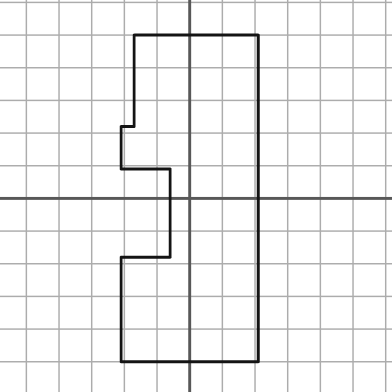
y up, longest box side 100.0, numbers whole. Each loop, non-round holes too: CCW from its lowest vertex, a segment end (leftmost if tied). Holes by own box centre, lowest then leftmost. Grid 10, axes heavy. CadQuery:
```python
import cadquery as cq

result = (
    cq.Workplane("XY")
    .moveTo(-21.0, -50.0)
    .lineTo(21.0, -50.0)
    .lineTo(21.0, 50.0)
    .lineTo(-17.0, 50.0)
    .lineTo(-17.0, 22.0)
    .lineTo(-21.0, 22.0)
    .lineTo(-21.0, 9.0)
    .lineTo(-6.0, 9.0)
    .lineTo(-6.0, -18.0)
    .lineTo(-21.0, -18.0)
    .close()
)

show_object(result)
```